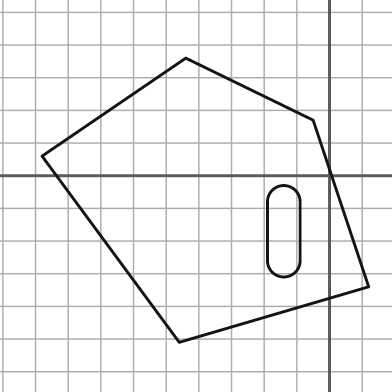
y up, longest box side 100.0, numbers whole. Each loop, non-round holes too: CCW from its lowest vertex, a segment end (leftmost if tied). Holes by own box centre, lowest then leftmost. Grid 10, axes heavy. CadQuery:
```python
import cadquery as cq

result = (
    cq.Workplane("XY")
    .moveTo(-46.0, -51.0)
    .lineTo(12.0, -34.0)
    .lineTo(-5.0, 17.0)
    .lineTo(-44.0, 36.0)
    .lineTo(-88.0, 6.0)
    .close()
    .moveTo(-19.0, -26.0)
    .threePointArc((-14.0, -31.0), (-9.0, -26.0))
    .lineTo(-9.0, -8.0)
    .threePointArc((-14.0, -3.0), (-19.0, -8.0))
    .close()
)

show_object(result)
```